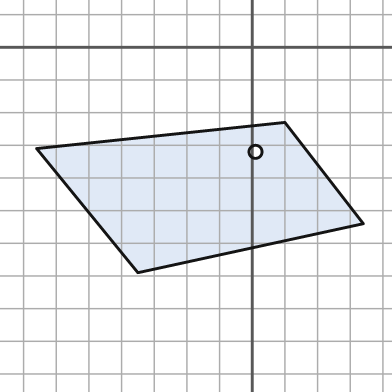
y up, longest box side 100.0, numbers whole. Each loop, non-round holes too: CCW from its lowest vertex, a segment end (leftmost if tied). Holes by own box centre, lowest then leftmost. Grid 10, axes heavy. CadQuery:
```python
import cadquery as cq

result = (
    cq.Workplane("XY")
    .moveTo(-35.0, -69.0)
    .lineTo(34.0, -54.0)
    .lineTo(10.0, -23.0)
    .lineTo(-66.0, -31.0)
    .close()
    .moveTo(1.0, -32.0)
    .circle(2.0)
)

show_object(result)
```